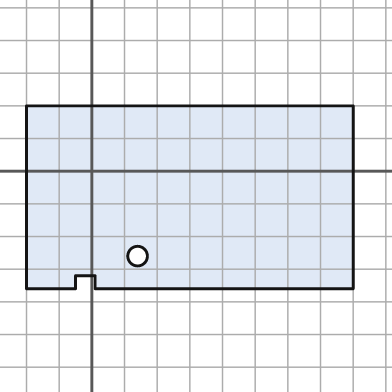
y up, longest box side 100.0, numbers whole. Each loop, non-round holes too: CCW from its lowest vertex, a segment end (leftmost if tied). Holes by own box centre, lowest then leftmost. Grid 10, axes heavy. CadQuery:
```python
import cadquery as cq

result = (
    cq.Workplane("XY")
    .moveTo(-20.0, -36.0)
    .lineTo(-5.0, -36.0)
    .lineTo(-5.0, -32.0)
    .lineTo(1.0, -32.0)
    .lineTo(1.0, -36.0)
    .lineTo(80.0, -36.0)
    .lineTo(80.0, 20.0)
    .lineTo(-20.0, 20.0)
    .close()
    .moveTo(14.0, -26.0)
    .circle(3.0)
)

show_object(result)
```